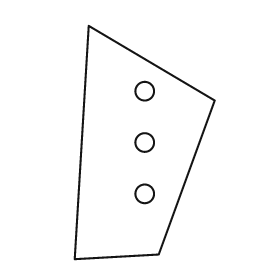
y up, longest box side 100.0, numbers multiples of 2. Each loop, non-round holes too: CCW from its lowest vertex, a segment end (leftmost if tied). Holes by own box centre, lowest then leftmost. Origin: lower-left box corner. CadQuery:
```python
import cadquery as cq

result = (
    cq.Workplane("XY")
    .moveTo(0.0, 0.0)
    .lineTo(36.0, 2.0)
    .lineTo(60.0, 68.0)
    .lineTo(6.0, 100.0)
    .close()
    .moveTo(30.0, 28.0)
    .circle(4.0)
    .moveTo(30.0, 50.0)
    .circle(4.0)
    .moveTo(30.0, 72.0)
    .circle(4.0)
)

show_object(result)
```